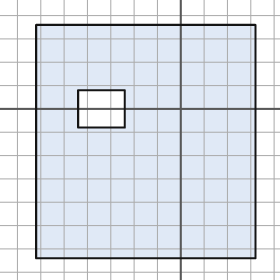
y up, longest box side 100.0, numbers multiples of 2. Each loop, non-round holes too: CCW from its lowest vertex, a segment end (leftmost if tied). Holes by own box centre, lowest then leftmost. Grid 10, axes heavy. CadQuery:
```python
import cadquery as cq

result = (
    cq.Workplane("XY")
    .moveTo(-62.0, -64.0)
    .lineTo(32.0, -64.0)
    .lineTo(32.0, 36.0)
    .lineTo(-62.0, 36.0)
    .close()
    .moveTo(-44.0, -8.0)
    .lineTo(-24.0, -8.0)
    .lineTo(-24.0, 8.0)
    .lineTo(-44.0, 8.0)
    .close()
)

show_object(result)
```